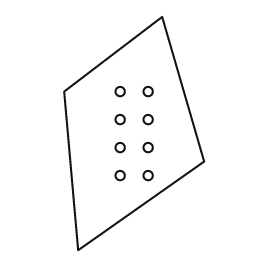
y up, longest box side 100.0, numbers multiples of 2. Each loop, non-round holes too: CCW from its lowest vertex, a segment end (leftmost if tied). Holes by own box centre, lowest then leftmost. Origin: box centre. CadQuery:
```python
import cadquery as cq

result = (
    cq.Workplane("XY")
    .moveTo(-24.0, -50.0)
    .lineTo(30.0, -12.0)
    .lineTo(12.0, 50.0)
    .lineTo(-30.0, 18.0)
    .close()
    .moveTo(-6.0, -18.0)
    .circle(2.0)
    .moveTo(6.0, -18.0)
    .circle(2.0)
    .moveTo(-6.0, -6.0)
    .circle(2.0)
    .moveTo(6.0, -6.0)
    .circle(2.0)
    .moveTo(-6.0, 6.0)
    .circle(2.0)
    .moveTo(6.0, 6.0)
    .circle(2.0)
    .moveTo(-6.0, 18.0)
    .circle(2.0)
    .moveTo(6.0, 18.0)
    .circle(2.0)
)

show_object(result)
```